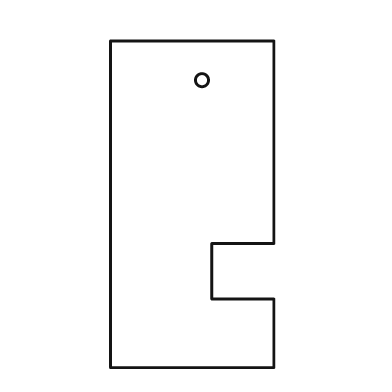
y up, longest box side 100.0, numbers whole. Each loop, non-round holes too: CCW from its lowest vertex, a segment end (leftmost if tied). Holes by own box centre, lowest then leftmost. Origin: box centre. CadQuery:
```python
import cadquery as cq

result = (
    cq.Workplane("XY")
    .moveTo(-25.0, -50.0)
    .lineTo(25.0, -50.0)
    .lineTo(25.0, -29.0)
    .lineTo(6.0, -29.0)
    .lineTo(6.0, -12.0)
    .lineTo(25.0, -12.0)
    .lineTo(25.0, 50.0)
    .lineTo(-25.0, 50.0)
    .close()
    .moveTo(3.0, 38.0)
    .circle(2.0)
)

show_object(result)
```